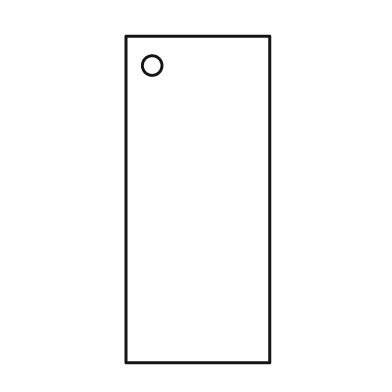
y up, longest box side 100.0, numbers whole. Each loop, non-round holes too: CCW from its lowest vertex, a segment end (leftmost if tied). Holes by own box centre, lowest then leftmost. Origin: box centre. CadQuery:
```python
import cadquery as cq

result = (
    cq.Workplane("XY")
    .moveTo(-22.0, -50.0)
    .lineTo(22.0, -50.0)
    .lineTo(22.0, 50.0)
    .lineTo(-22.0, 50.0)
    .close()
    .moveTo(-14.0, 41.0)
    .circle(3.0)
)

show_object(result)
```